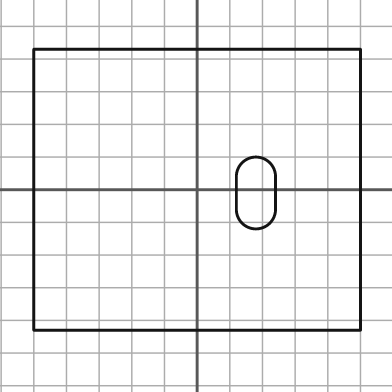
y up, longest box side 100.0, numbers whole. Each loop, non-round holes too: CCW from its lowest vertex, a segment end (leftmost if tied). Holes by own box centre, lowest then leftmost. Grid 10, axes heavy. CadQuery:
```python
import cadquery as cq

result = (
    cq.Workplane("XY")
    .moveTo(-50.0, -43.0)
    .lineTo(50.0, -43.0)
    .lineTo(50.0, 43.0)
    .lineTo(-50.0, 43.0)
    .close()
    .moveTo(12.0, -6.0)
    .threePointArc((18.0, -12.0), (24.0, -6.0))
    .lineTo(24.0, 4.0)
    .threePointArc((18.0, 10.0), (12.0, 4.0))
    .close()
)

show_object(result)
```